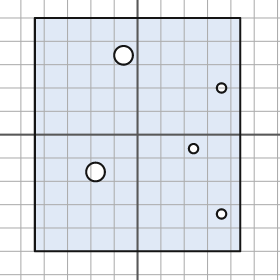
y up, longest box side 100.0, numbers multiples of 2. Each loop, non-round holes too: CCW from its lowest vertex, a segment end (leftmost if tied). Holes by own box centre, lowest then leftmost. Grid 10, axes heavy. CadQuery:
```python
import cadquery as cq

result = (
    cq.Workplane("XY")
    .moveTo(-44.0, -50.0)
    .lineTo(44.0, -50.0)
    .lineTo(44.0, 50.0)
    .lineTo(-44.0, 50.0)
    .close()
    .moveTo(36.0, -34.0)
    .circle(2.0)
    .moveTo(-18.0, -16.0)
    .circle(4.0)
    .moveTo(24.0, -6.0)
    .circle(2.0)
    .moveTo(36.0, 20.0)
    .circle(2.0)
    .moveTo(-6.0, 34.0)
    .circle(4.0)
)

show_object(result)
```